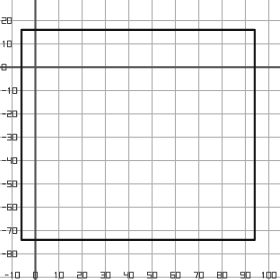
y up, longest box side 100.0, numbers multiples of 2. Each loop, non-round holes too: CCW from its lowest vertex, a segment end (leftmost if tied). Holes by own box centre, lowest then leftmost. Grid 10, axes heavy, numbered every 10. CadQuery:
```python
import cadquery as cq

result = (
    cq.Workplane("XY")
    .moveTo(-6.0, -74.0)
    .lineTo(94.0, -74.0)
    .lineTo(94.0, 16.0)
    .lineTo(-6.0, 16.0)
    .close()
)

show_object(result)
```